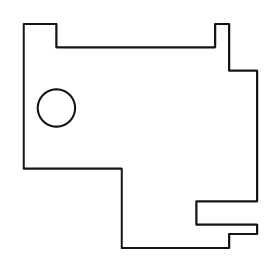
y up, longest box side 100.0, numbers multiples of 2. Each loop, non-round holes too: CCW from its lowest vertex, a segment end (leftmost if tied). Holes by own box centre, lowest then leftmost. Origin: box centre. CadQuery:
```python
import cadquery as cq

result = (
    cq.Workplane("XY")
    .moveTo(-8.0, -48.0)
    .lineTo(38.0, -48.0)
    .lineTo(38.0, -42.0)
    .lineTo(50.0, -42.0)
    .lineTo(50.0, -38.0)
    .lineTo(24.0, -38.0)
    .lineTo(24.0, -28.0)
    .lineTo(50.0, -28.0)
    .lineTo(50.0, 28.0)
    .lineTo(38.0, 28.0)
    .lineTo(38.0, 48.0)
    .lineTo(32.0, 48.0)
    .lineTo(32.0, 38.0)
    .lineTo(-36.0, 38.0)
    .lineTo(-36.0, 48.0)
    .lineTo(-50.0, 48.0)
    .lineTo(-50.0, -14.0)
    .lineTo(-8.0, -14.0)
    .close()
    .moveTo(-36.0, 12.0)
    .circle(8.0)
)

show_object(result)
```